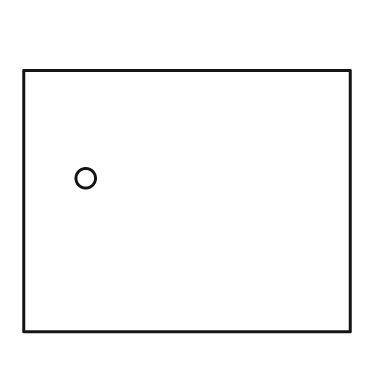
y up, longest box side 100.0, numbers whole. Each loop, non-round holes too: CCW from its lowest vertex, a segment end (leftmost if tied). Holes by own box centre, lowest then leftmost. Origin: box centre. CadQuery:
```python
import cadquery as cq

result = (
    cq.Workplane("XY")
    .moveTo(-50.0, -40.0)
    .lineTo(50.0, -40.0)
    .lineTo(50.0, 40.0)
    .lineTo(-50.0, 40.0)
    .close()
    .moveTo(-31.0, 7.0)
    .circle(3.0)
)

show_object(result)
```